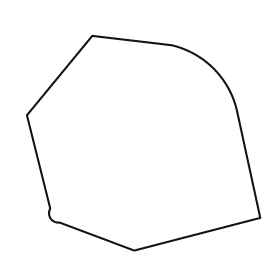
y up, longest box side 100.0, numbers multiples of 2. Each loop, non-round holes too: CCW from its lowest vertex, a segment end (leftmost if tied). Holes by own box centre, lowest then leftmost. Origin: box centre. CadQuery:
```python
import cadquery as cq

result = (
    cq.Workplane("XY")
    .moveTo(-4.0, -46.0)
    .lineTo(50.0, -32.0)
    .lineTo(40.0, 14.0)
    .threePointArc((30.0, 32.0), (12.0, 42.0))
    .lineTo(-22.0, 46.0)
    .lineTo(-50.0, 12.0)
    .lineTo(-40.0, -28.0)
    .threePointArc((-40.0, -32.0), (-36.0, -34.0))
    .close()
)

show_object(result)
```